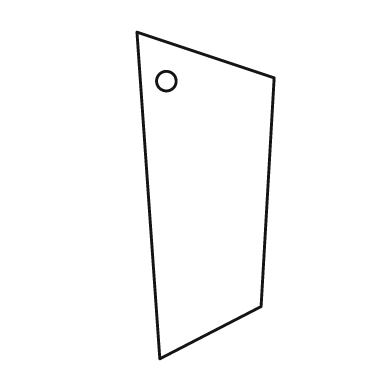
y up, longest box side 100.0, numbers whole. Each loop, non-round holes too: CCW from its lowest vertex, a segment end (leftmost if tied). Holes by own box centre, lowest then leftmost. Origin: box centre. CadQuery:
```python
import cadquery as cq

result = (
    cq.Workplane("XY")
    .moveTo(-14.0, -50.0)
    .lineTo(17.0, -34.0)
    .lineTo(21.0, 36.0)
    .lineTo(-21.0, 50.0)
    .close()
    .moveTo(-12.0, 35.0)
    .circle(3.0)
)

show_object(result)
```